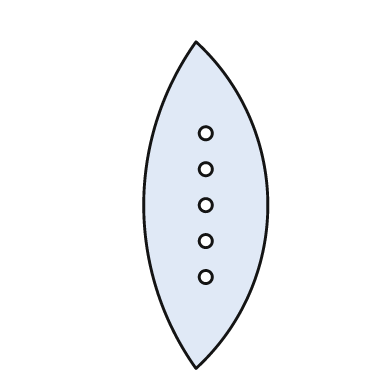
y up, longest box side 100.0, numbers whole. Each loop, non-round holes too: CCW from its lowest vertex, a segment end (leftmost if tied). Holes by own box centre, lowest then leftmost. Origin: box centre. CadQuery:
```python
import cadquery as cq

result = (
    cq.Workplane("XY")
    .moveTo(-3.0, -50.0)
    .threePointArc((19.0, 0.0), (-3.0, 50.0))
    .threePointArc((-19.0, 0.0), (-3.0, -50.0))
    .close()
    .moveTo(0.0, -22.0)
    .circle(2.0)
    .moveTo(0.0, -11.0)
    .circle(2.0)
    .moveTo(0.0, 0.0)
    .circle(2.0)
    .moveTo(0.0, 11.0)
    .circle(2.0)
    .moveTo(0.0, 22.0)
    .circle(2.0)
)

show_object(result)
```